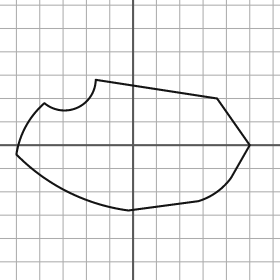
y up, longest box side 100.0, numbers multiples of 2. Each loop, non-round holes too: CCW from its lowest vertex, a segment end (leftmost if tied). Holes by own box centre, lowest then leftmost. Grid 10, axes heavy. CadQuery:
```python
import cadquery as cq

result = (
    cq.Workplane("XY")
    .moveTo(-2.0, -28.0)
    .lineTo(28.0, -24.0)
    .threePointArc((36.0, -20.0), (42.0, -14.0))
    .lineTo(50.0, 0.0)
    .lineTo(36.0, 20.0)
    .lineTo(-16.0, 28.0)
    .threePointArc((-24.0, 16.0), (-38.0, 18.0))
    .threePointArc((-46.0, 8.0), (-50.0, -4.0))
    .threePointArc((-28.0, -20.0), (-2.0, -28.0))
    .close()
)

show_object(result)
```